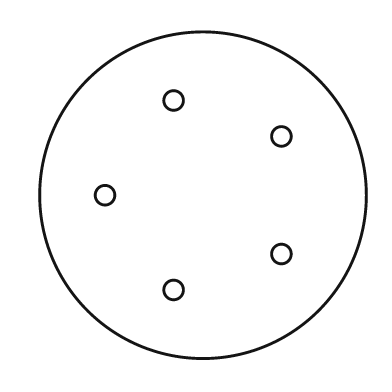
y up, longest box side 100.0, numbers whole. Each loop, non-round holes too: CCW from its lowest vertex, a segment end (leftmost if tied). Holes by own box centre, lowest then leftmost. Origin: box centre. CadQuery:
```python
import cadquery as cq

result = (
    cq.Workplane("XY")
    .moveTo(0.0, 0.0)
    .circle(50.0)
    .moveTo(-9.0, -29.0)
    .circle(3.0)
    .moveTo(24.0, -18.0)
    .circle(3.0)
    .moveTo(-30.0, 0.0)
    .circle(3.0)
    .moveTo(24.0, 18.0)
    .circle(3.0)
    .moveTo(-9.0, 29.0)
    .circle(3.0)
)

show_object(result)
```